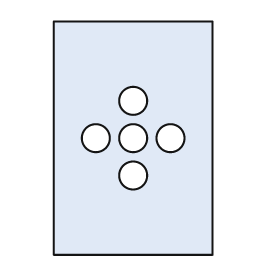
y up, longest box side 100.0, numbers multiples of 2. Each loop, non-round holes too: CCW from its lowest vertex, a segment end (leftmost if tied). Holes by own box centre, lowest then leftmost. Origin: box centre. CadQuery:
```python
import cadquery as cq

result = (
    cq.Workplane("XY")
    .moveTo(-34.0, -50.0)
    .lineTo(34.0, -50.0)
    .lineTo(34.0, 50.0)
    .lineTo(-34.0, 50.0)
    .close()
    .moveTo(0.0, -16.0)
    .circle(6.0)
    .moveTo(-16.0, 0.0)
    .circle(6.0)
    .moveTo(0.0, 0.0)
    .circle(6.0)
    .moveTo(16.0, 0.0)
    .circle(6.0)
    .moveTo(0.0, 16.0)
    .circle(6.0)
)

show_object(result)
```